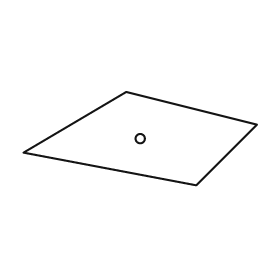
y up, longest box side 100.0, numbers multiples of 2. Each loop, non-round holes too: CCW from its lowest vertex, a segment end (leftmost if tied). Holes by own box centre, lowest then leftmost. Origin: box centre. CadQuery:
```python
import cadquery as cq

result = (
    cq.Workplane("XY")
    .moveTo(24.0, -20.0)
    .lineTo(50.0, 6.0)
    .lineTo(-6.0, 20.0)
    .lineTo(-50.0, -6.0)
    .close()
    .moveTo(0.0, 0.0)
    .circle(2.0)
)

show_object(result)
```